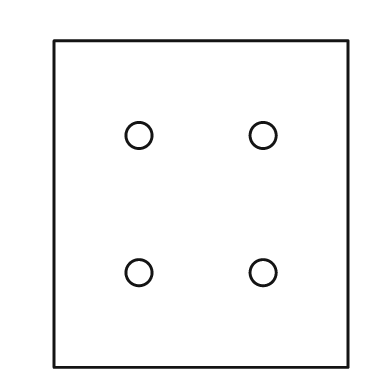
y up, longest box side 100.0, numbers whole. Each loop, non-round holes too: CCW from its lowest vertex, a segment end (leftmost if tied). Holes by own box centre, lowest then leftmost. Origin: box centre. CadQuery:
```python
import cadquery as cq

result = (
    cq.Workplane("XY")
    .moveTo(-45.0, -50.0)
    .lineTo(45.0, -50.0)
    .lineTo(45.0, 50.0)
    .lineTo(-45.0, 50.0)
    .close()
    .moveTo(-19.0, -21.0)
    .circle(4.0)
    .moveTo(19.0, -21.0)
    .circle(4.0)
    .moveTo(-19.0, 21.0)
    .circle(4.0)
    .moveTo(19.0, 21.0)
    .circle(4.0)
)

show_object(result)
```